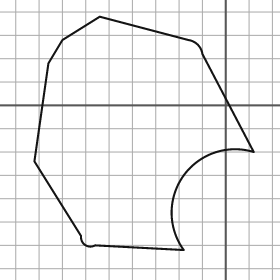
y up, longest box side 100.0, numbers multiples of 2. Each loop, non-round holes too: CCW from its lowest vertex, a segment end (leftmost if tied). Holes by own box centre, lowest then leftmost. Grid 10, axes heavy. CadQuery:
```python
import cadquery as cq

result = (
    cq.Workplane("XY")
    .moveTo(-18.0, -62.0)
    .threePointArc((-18.0, -30.0), (12.0, -20.0))
    .lineTo(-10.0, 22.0)
    .threePointArc((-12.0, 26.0), (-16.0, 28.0))
    .lineTo(-54.0, 38.0)
    .lineTo(-70.0, 28.0)
    .lineTo(-76.0, 18.0)
    .lineTo(-82.0, -24.0)
    .lineTo(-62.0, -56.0)
    .threePointArc((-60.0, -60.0), (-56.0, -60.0))
    .close()
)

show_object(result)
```